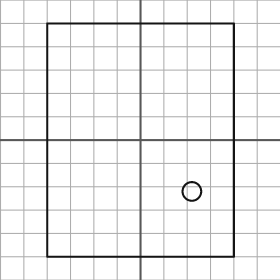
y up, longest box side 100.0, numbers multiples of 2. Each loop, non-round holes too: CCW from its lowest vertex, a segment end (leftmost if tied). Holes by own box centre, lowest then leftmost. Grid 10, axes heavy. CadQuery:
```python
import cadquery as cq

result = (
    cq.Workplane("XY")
    .moveTo(-40.0, -50.0)
    .lineTo(40.0, -50.0)
    .lineTo(40.0, 50.0)
    .lineTo(-40.0, 50.0)
    .close()
    .moveTo(22.0, -22.0)
    .circle(4.0)
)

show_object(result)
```